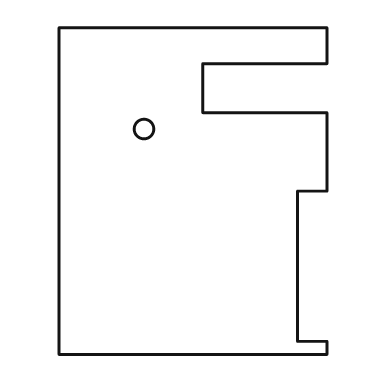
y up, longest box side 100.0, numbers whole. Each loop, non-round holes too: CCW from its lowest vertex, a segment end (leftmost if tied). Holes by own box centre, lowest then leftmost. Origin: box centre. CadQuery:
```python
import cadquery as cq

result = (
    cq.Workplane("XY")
    .moveTo(-41.0, -50.0)
    .lineTo(41.0, -50.0)
    .lineTo(41.0, -46.0)
    .lineTo(32.0, -46.0)
    .lineTo(32.0, 0.0)
    .lineTo(41.0, 0.0)
    .lineTo(41.0, 24.0)
    .lineTo(3.0, 24.0)
    .lineTo(3.0, 39.0)
    .lineTo(41.0, 39.0)
    .lineTo(41.0, 50.0)
    .lineTo(-41.0, 50.0)
    .close()
    .moveTo(-15.0, 19.0)
    .circle(3.0)
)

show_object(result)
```